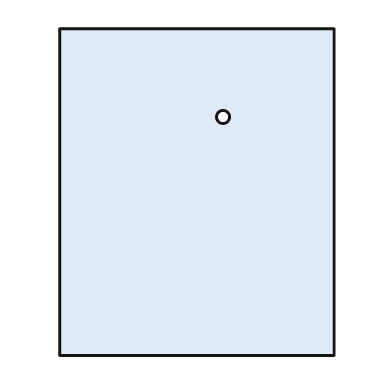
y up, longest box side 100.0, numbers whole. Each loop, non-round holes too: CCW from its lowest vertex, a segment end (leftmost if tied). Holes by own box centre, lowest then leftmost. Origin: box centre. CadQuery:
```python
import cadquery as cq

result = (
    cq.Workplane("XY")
    .moveTo(-42.0, -50.0)
    .lineTo(42.0, -50.0)
    .lineTo(42.0, 50.0)
    .lineTo(-42.0, 50.0)
    .close()
    .moveTo(8.0, 23.0)
    .circle(2.0)
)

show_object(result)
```